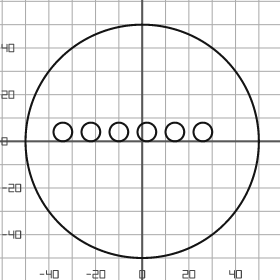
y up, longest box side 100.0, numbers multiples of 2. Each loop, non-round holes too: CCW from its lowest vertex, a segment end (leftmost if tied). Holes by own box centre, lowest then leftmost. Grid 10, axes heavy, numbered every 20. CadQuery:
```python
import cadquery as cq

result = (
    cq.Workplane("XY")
    .moveTo(0.0, 0.0)
    .circle(50.0)
    .moveTo(-34.0, 4.0)
    .circle(4.0)
    .moveTo(-22.0, 4.0)
    .circle(4.0)
    .moveTo(-10.0, 4.0)
    .circle(4.0)
    .moveTo(2.0, 4.0)
    .circle(4.0)
    .moveTo(14.0, 4.0)
    .circle(4.0)
    .moveTo(26.0, 4.0)
    .circle(4.0)
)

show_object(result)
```